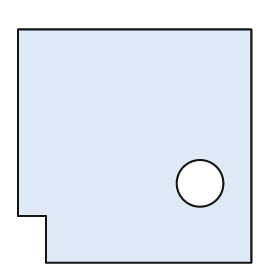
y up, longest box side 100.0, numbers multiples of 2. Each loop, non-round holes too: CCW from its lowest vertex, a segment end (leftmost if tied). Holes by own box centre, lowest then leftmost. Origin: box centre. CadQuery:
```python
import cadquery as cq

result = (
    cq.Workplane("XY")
    .moveTo(-38.0, -50.0)
    .lineTo(50.0, -50.0)
    .lineTo(50.0, 50.0)
    .lineTo(-50.0, 50.0)
    .lineTo(-50.0, -30.0)
    .lineTo(-38.0, -30.0)
    .close()
    .moveTo(28.0, -16.0)
    .circle(10.0)
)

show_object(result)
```